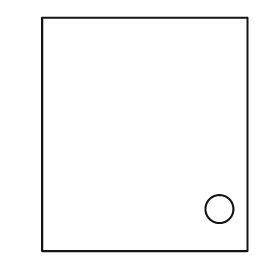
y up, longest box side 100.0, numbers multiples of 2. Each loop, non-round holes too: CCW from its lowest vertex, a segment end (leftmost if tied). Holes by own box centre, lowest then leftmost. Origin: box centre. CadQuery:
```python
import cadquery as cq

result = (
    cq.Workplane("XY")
    .moveTo(-44.0, -50.0)
    .lineTo(44.0, -50.0)
    .lineTo(44.0, 50.0)
    .lineTo(-44.0, 50.0)
    .close()
    .moveTo(32.0, -32.0)
    .circle(6.0)
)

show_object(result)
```